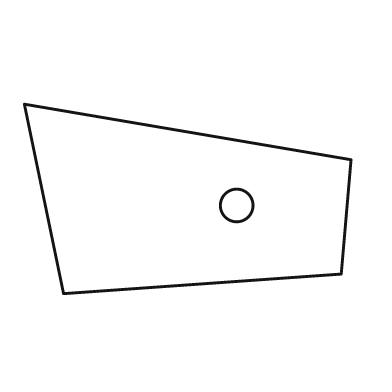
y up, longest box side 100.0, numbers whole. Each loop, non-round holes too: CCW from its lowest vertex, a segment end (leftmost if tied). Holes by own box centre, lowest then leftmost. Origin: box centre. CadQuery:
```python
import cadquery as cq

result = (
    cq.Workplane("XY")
    .moveTo(-38.0, -29.0)
    .lineTo(47.0, -23.0)
    .lineTo(50.0, 12.0)
    .lineTo(-50.0, 29.0)
    .close()
    .moveTo(15.0, -2.0)
    .circle(5.0)
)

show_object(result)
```